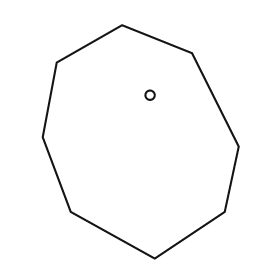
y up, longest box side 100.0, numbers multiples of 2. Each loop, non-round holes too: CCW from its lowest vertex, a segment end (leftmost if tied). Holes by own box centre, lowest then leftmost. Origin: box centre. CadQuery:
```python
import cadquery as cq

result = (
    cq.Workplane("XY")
    .moveTo(6.0, -50.0)
    .lineTo(36.0, -30.0)
    .lineTo(42.0, -2.0)
    .lineTo(22.0, 38.0)
    .lineTo(-8.0, 50.0)
    .lineTo(-36.0, 34.0)
    .lineTo(-42.0, 2.0)
    .lineTo(-30.0, -30.0)
    .close()
    .moveTo(4.0, 20.0)
    .circle(2.0)
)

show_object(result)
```